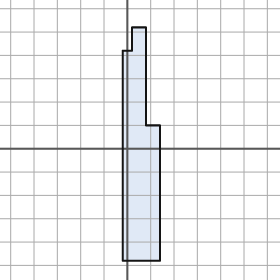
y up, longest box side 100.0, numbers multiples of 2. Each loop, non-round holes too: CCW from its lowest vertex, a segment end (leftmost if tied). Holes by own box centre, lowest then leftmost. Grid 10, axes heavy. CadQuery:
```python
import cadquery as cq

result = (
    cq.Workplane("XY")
    .moveTo(-2.0, -48.0)
    .lineTo(14.0, -48.0)
    .lineTo(14.0, 10.0)
    .lineTo(8.0, 10.0)
    .lineTo(8.0, 52.0)
    .lineTo(2.0, 52.0)
    .lineTo(2.0, 42.0)
    .lineTo(-2.0, 42.0)
    .close()
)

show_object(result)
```